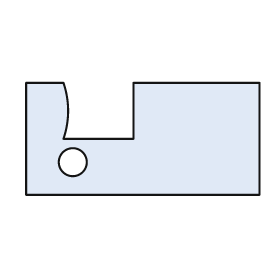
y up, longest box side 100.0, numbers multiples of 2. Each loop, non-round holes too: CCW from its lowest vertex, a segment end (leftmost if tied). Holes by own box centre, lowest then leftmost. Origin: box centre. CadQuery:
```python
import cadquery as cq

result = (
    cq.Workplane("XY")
    .moveTo(-50.0, -24.0)
    .lineTo(50.0, -24.0)
    .lineTo(50.0, 24.0)
    .lineTo(-4.0, 24.0)
    .lineTo(-4.0, 0.0)
    .lineTo(-34.0, 0.0)
    .threePointArc((-32.0, 12.0), (-34.0, 24.0))
    .lineTo(-50.0, 24.0)
    .close()
    .moveTo(-30.0, -10.0)
    .circle(6.0)
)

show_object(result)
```